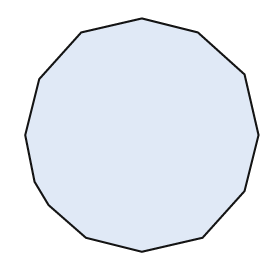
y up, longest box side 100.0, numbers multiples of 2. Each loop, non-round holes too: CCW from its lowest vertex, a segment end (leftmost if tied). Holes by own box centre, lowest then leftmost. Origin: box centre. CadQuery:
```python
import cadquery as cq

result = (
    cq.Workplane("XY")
    .moveTo(0.0, -50.0)
    .lineTo(26.0, -44.0)
    .lineTo(44.0, -24.0)
    .lineTo(50.0, 0.0)
    .lineTo(44.0, 26.0)
    .lineTo(24.0, 44.0)
    .lineTo(0.0, 50.0)
    .lineTo(-26.0, 44.0)
    .lineTo(-44.0, 24.0)
    .lineTo(-50.0, 0.0)
    .lineTo(-46.0, -20.0)
    .lineTo(-40.0, -30.0)
    .lineTo(-24.0, -44.0)
    .close()
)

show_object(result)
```